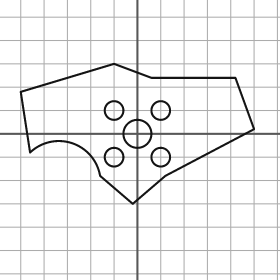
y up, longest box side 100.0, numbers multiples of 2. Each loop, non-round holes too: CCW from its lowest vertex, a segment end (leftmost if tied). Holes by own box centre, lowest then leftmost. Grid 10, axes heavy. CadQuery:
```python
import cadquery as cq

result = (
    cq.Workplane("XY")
    .moveTo(-2.0, -30.0)
    .lineTo(12.0, -18.0)
    .lineTo(50.0, 2.0)
    .lineTo(42.0, 24.0)
    .lineTo(6.0, 24.0)
    .lineTo(-10.0, 30.0)
    .lineTo(-50.0, 18.0)
    .lineTo(-46.0, -8.0)
    .threePointArc((-28.0, -4.0), (-16.0, -18.0))
    .close()
    .moveTo(-10.0, -10.0)
    .circle(4.0)
    .moveTo(10.0, -10.0)
    .circle(4.0)
    .moveTo(0.0, 0.0)
    .circle(6.0)
    .moveTo(-10.0, 10.0)
    .circle(4.0)
    .moveTo(10.0, 10.0)
    .circle(4.0)
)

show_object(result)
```